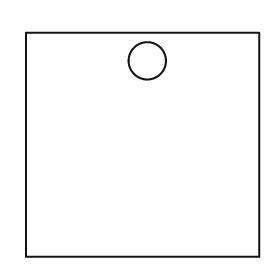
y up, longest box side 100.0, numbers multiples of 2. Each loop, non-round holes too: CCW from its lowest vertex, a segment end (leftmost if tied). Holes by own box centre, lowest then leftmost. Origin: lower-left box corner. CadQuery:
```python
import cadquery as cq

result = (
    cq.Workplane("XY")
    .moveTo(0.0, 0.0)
    .lineTo(100.0, 0.0)
    .lineTo(100.0, 96.0)
    .lineTo(0.0, 96.0)
    .close()
    .moveTo(52.0, 84.0)
    .circle(8.0)
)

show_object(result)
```